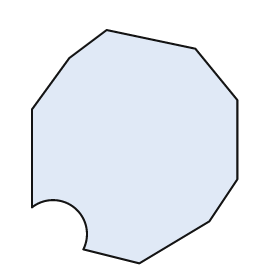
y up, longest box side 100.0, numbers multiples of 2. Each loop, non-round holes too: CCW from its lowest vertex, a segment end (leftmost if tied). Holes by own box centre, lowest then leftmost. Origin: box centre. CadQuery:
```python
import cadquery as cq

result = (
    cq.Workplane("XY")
    .moveTo(2.0, -50.0)
    .lineTo(32.0, -32.0)
    .lineTo(44.0, -14.0)
    .lineTo(44.0, 20.0)
    .lineTo(26.0, 42.0)
    .lineTo(-12.0, 50.0)
    .lineTo(-28.0, 38.0)
    .lineTo(-44.0, 16.0)
    .lineTo(-44.0, -26.0)
    .threePointArc((-26.0, -26.0), (-22.0, -44.0))
    .close()
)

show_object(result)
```